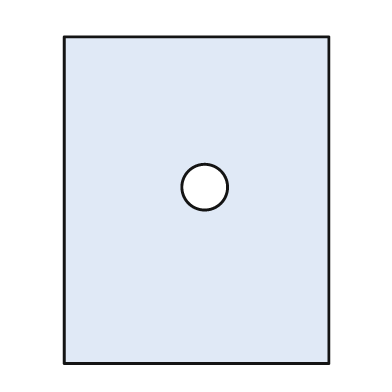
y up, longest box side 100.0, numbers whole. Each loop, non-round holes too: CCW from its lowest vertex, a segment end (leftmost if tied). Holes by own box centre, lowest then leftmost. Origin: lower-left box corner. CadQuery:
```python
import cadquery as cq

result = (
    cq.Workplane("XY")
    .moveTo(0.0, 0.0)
    .lineTo(81.0, 0.0)
    .lineTo(81.0, 100.0)
    .lineTo(0.0, 100.0)
    .close()
    .moveTo(43.0, 54.0)
    .circle(7.0)
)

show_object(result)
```